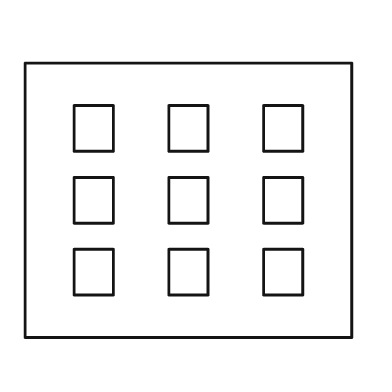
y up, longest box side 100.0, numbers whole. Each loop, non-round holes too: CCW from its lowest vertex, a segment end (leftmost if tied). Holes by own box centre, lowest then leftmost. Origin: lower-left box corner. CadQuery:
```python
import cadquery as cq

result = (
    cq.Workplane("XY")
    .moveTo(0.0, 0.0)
    .lineTo(100.0, 0.0)
    .lineTo(100.0, 84.0)
    .lineTo(0.0, 84.0)
    .close()
    .moveTo(15.0, 13.0)
    .lineTo(27.0, 13.0)
    .lineTo(27.0, 27.0)
    .lineTo(15.0, 27.0)
    .close()
    .moveTo(44.0, 13.0)
    .lineTo(56.0, 13.0)
    .lineTo(56.0, 27.0)
    .lineTo(44.0, 27.0)
    .close()
    .moveTo(73.0, 13.0)
    .lineTo(85.0, 13.0)
    .lineTo(85.0, 27.0)
    .lineTo(73.0, 27.0)
    .close()
    .moveTo(15.0, 35.0)
    .lineTo(27.0, 35.0)
    .lineTo(27.0, 49.0)
    .lineTo(15.0, 49.0)
    .close()
    .moveTo(44.0, 35.0)
    .lineTo(56.0, 35.0)
    .lineTo(56.0, 49.0)
    .lineTo(44.0, 49.0)
    .close()
    .moveTo(73.0, 35.0)
    .lineTo(85.0, 35.0)
    .lineTo(85.0, 49.0)
    .lineTo(73.0, 49.0)
    .close()
    .moveTo(15.0, 57.0)
    .lineTo(27.0, 57.0)
    .lineTo(27.0, 71.0)
    .lineTo(15.0, 71.0)
    .close()
    .moveTo(44.0, 57.0)
    .lineTo(56.0, 57.0)
    .lineTo(56.0, 71.0)
    .lineTo(44.0, 71.0)
    .close()
    .moveTo(73.0, 57.0)
    .lineTo(85.0, 57.0)
    .lineTo(85.0, 71.0)
    .lineTo(73.0, 71.0)
    .close()
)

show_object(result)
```